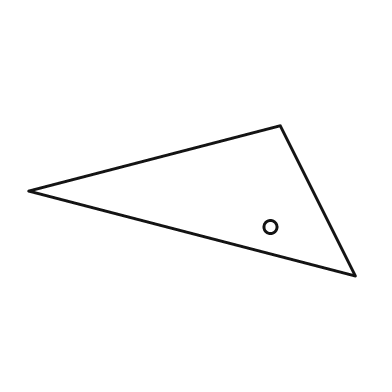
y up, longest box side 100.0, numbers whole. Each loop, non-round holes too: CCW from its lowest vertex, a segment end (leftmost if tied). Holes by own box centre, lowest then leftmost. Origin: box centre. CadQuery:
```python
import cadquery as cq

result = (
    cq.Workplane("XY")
    .moveTo(50.0, -23.0)
    .lineTo(27.0, 23.0)
    .lineTo(-50.0, 3.0)
    .close()
    .moveTo(24.0, -8.0)
    .circle(2.0)
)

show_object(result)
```